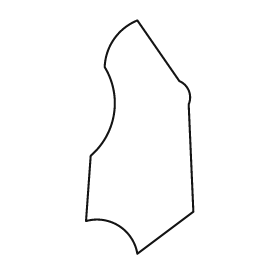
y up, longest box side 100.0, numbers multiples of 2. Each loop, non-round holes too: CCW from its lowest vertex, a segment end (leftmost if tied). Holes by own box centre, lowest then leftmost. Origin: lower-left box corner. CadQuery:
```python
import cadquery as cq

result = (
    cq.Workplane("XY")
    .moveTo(22.0, 0.0)
    .lineTo(46.0, 18.0)
    .lineTo(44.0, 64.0)
    .threePointArc((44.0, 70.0), (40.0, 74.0))
    .lineTo(22.0, 100.0)
    .threePointArc((12.0, 92.0), (8.0, 80.0))
    .threePointArc((12.0, 60.0), (2.0, 42.0))
    .lineTo(0.0, 14.0)
    .threePointArc((14.0, 12.0), (22.0, 0.0))
    .close()
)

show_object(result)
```